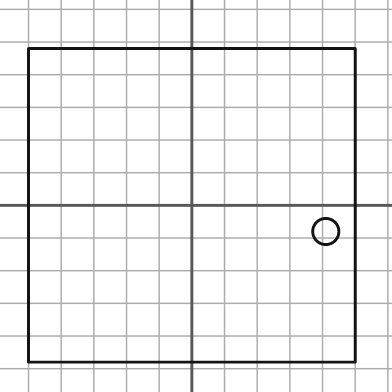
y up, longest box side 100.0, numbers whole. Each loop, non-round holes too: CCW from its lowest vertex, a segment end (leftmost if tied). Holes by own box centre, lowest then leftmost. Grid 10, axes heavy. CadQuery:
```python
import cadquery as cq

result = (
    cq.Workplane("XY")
    .moveTo(-50.0, -48.0)
    .lineTo(50.0, -48.0)
    .lineTo(50.0, 48.0)
    .lineTo(-50.0, 48.0)
    .close()
    .moveTo(41.0, -8.0)
    .circle(4.0)
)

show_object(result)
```